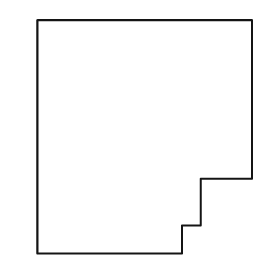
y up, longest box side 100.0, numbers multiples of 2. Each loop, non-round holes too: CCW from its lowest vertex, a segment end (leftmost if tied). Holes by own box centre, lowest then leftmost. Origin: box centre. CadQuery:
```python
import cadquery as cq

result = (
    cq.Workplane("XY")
    .moveTo(-46.0, -50.0)
    .lineTo(16.0, -50.0)
    .lineTo(16.0, -38.0)
    .lineTo(24.0, -38.0)
    .lineTo(24.0, -18.0)
    .lineTo(46.0, -18.0)
    .lineTo(46.0, 50.0)
    .lineTo(-46.0, 50.0)
    .close()
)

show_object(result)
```